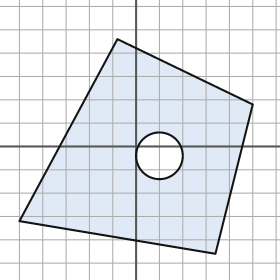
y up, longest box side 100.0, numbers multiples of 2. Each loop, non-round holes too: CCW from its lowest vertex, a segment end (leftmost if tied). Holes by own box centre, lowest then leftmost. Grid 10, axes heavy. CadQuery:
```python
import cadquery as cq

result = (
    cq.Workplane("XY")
    .moveTo(34.0, -46.0)
    .lineTo(50.0, 18.0)
    .lineTo(-8.0, 46.0)
    .lineTo(-50.0, -32.0)
    .close()
    .moveTo(10.0, -4.0)
    .circle(10.0)
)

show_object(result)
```